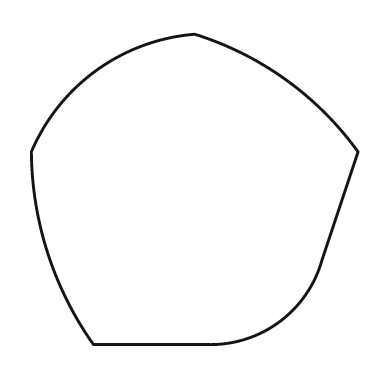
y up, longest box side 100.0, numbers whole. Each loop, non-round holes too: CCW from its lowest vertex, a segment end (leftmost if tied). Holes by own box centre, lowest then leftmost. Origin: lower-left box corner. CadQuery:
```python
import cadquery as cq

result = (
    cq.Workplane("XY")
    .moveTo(19.0, 0.0)
    .lineTo(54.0, 0.0)
    .threePointArc((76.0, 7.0), (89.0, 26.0))
    .lineTo(100.0, 59.0)
    .threePointArc((78.0, 81.0), (50.0, 95.0))
    .threePointArc((20.0, 84.0), (0.0, 59.0))
    .threePointArc((5.0, 28.0), (19.0, 0.0))
    .close()
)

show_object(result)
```